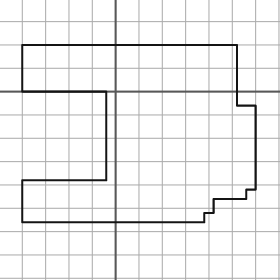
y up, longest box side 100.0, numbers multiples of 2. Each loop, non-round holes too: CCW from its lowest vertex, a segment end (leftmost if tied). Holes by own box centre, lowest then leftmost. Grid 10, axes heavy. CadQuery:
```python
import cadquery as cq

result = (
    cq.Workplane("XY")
    .moveTo(-40.0, -56.0)
    .lineTo(38.0, -56.0)
    .lineTo(38.0, -52.0)
    .lineTo(42.0, -52.0)
    .lineTo(42.0, -46.0)
    .lineTo(56.0, -46.0)
    .lineTo(56.0, -42.0)
    .lineTo(60.0, -42.0)
    .lineTo(60.0, -6.0)
    .lineTo(52.0, -6.0)
    .lineTo(52.0, 20.0)
    .lineTo(-40.0, 20.0)
    .lineTo(-40.0, 0.0)
    .lineTo(-4.0, 0.0)
    .lineTo(-4.0, -38.0)
    .lineTo(-40.0, -38.0)
    .close()
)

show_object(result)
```